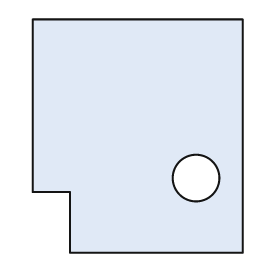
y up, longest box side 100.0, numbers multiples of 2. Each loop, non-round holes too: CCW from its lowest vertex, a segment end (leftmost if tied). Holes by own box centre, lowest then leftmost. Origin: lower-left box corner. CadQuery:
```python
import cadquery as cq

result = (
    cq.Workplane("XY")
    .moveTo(16.0, 0.0)
    .lineTo(90.0, 0.0)
    .lineTo(90.0, 100.0)
    .lineTo(0.0, 100.0)
    .lineTo(0.0, 26.0)
    .lineTo(16.0, 26.0)
    .close()
    .moveTo(70.0, 32.0)
    .circle(10.0)
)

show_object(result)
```